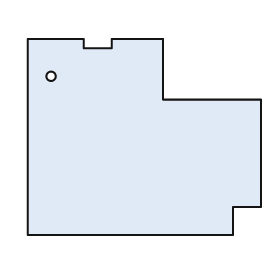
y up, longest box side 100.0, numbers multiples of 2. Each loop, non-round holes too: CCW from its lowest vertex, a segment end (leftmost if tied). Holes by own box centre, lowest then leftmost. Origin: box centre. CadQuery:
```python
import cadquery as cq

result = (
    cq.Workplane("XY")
    .moveTo(-50.0, -42.0)
    .lineTo(38.0, -42.0)
    .lineTo(38.0, -30.0)
    .lineTo(50.0, -30.0)
    .lineTo(50.0, 16.0)
    .lineTo(8.0, 16.0)
    .lineTo(8.0, 42.0)
    .lineTo(-14.0, 42.0)
    .lineTo(-14.0, 38.0)
    .lineTo(-26.0, 38.0)
    .lineTo(-26.0, 42.0)
    .lineTo(-50.0, 42.0)
    .close()
    .moveTo(-40.0, 26.0)
    .circle(2.0)
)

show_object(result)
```